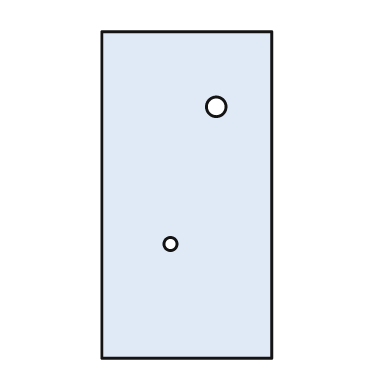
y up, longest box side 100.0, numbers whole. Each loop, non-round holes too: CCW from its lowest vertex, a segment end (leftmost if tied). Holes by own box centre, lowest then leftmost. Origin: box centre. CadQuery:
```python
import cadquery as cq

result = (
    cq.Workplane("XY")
    .moveTo(-26.0, -50.0)
    .lineTo(26.0, -50.0)
    .lineTo(26.0, 50.0)
    .lineTo(-26.0, 50.0)
    .close()
    .moveTo(-5.0, -15.0)
    .circle(2.0)
    .moveTo(9.0, 27.0)
    .circle(3.0)
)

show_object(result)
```